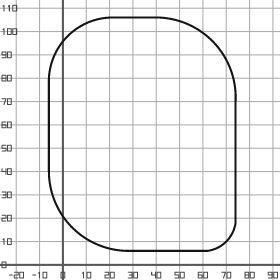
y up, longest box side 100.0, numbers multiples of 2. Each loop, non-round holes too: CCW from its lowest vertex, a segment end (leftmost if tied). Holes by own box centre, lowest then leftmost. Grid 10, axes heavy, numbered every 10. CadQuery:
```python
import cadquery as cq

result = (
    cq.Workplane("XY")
    .moveTo(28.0, 6.0)
    .lineTo(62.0, 6.0)
    .threePointArc((70.0, 10.0), (74.0, 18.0))
    .lineTo(74.0, 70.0)
    .threePointArc((64.0, 96.0), (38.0, 106.0))
    .lineTo(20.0, 106.0)
    .threePointArc((2.0, 98.0), (-6.0, 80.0))
    .lineTo(-6.0, 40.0)
    .threePointArc((4.0, 16.0), (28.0, 6.0))
    .close()
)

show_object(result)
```